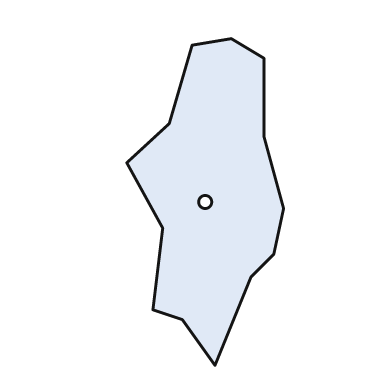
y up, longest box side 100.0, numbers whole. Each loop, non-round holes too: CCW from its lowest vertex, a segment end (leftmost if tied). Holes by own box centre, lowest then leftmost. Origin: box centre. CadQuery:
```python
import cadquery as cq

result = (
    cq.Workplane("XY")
    .moveTo(3.0, -50.0)
    .lineTo(14.0, -23.0)
    .lineTo(21.0, -16.0)
    .lineTo(24.0, -2.0)
    .lineTo(18.0, 20.0)
    .lineTo(18.0, 44.0)
    .lineTo(8.0, 50.0)
    .lineTo(-4.0, 48.0)
    .lineTo(-11.0, 24.0)
    .lineTo(-24.0, 12.0)
    .lineTo(-13.0, -8.0)
    .lineTo(-16.0, -33.0)
    .lineTo(-7.0, -36.0)
    .close()
    .moveTo(0.0, 0.0)
    .circle(2.0)
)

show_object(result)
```